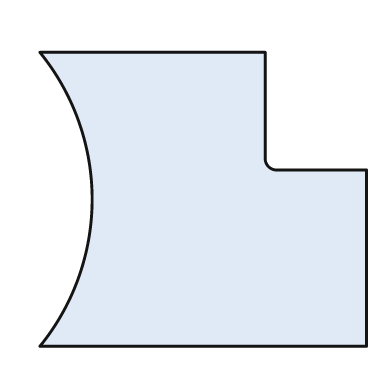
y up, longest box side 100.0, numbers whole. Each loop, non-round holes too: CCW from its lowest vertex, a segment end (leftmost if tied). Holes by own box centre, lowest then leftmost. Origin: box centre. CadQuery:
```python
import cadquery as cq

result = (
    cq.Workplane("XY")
    .moveTo(-50.0, -45.0)
    .lineTo(50.0, -45.0)
    .lineTo(50.0, 9.0)
    .lineTo(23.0, 9.0)
    .threePointArc((20.0, 10.0), (19.0, 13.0))
    .lineTo(19.0, 45.0)
    .lineTo(-50.0, 45.0)
    .threePointArc((-34.0, 0.0), (-50.0, -45.0))
    .close()
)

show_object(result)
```